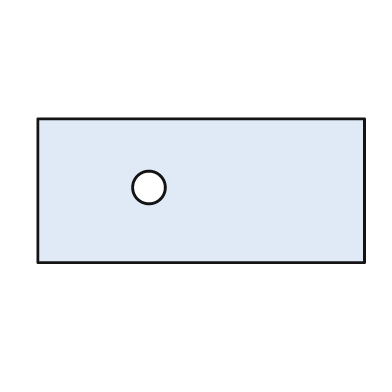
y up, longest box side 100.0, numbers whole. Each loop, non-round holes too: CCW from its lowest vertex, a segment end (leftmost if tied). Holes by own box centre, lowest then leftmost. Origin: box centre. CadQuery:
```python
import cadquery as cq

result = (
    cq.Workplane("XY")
    .moveTo(-50.0, -22.0)
    .lineTo(50.0, -22.0)
    .lineTo(50.0, 22.0)
    .lineTo(-50.0, 22.0)
    .close()
    .moveTo(-16.0, 1.0)
    .circle(5.0)
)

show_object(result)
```